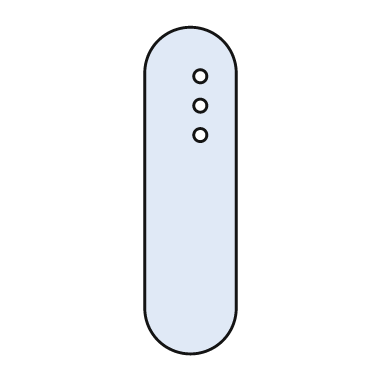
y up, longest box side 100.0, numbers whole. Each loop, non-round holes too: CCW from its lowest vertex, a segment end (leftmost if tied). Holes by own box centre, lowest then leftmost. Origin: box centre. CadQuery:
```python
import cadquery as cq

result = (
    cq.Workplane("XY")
    .moveTo(-14.0, -36.0)
    .threePointArc((0.0, -50.0), (14.0, -36.0))
    .lineTo(14.0, 36.0)
    .threePointArc((0.0, 50.0), (-14.0, 36.0))
    .close()
    .moveTo(3.0, 17.0)
    .circle(2.0)
    .moveTo(3.0, 26.0)
    .circle(2.0)
    .moveTo(3.0, 35.0)
    .circle(2.0)
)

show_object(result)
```